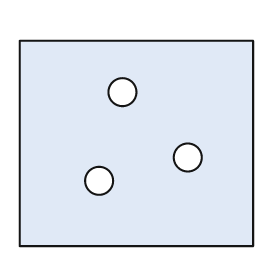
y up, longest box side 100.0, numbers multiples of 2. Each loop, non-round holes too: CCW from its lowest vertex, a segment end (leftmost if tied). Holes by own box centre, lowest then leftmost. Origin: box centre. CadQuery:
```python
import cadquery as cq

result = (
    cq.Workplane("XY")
    .moveTo(-50.0, -44.0)
    .lineTo(50.0, -44.0)
    .lineTo(50.0, 44.0)
    .lineTo(-50.0, 44.0)
    .close()
    .moveTo(-16.0, -16.0)
    .circle(6.0)
    .moveTo(22.0, -6.0)
    .circle(6.0)
    .moveTo(-6.0, 22.0)
    .circle(6.0)
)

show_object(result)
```